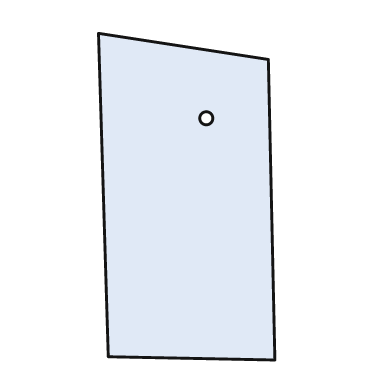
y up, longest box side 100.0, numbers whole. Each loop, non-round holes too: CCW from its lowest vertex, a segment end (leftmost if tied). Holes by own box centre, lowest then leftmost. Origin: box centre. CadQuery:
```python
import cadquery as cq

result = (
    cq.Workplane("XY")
    .moveTo(27.0, -50.0)
    .lineTo(25.0, 42.0)
    .lineTo(-27.0, 50.0)
    .lineTo(-24.0, -49.0)
    .close()
    .moveTo(6.0, 24.0)
    .circle(2.0)
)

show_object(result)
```